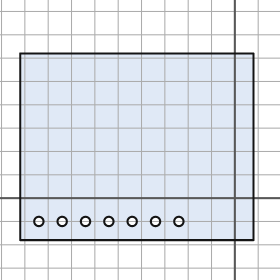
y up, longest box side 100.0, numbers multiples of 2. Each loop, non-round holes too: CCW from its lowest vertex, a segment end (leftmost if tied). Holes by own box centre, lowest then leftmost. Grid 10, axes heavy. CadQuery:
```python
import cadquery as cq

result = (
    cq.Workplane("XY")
    .moveTo(-92.0, -18.0)
    .lineTo(8.0, -18.0)
    .lineTo(8.0, 62.0)
    .lineTo(-92.0, 62.0)
    .close()
    .moveTo(-84.0, -10.0)
    .circle(2.0)
    .moveTo(-74.0, -10.0)
    .circle(2.0)
    .moveTo(-64.0, -10.0)
    .circle(2.0)
    .moveTo(-54.0, -10.0)
    .circle(2.0)
    .moveTo(-44.0, -10.0)
    .circle(2.0)
    .moveTo(-34.0, -10.0)
    .circle(2.0)
    .moveTo(-24.0, -10.0)
    .circle(2.0)
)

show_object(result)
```